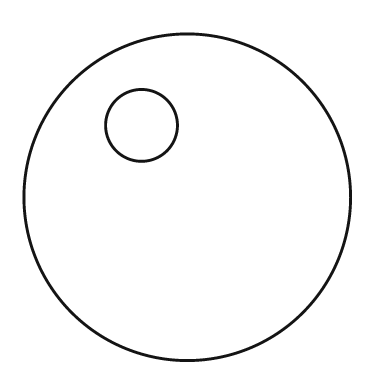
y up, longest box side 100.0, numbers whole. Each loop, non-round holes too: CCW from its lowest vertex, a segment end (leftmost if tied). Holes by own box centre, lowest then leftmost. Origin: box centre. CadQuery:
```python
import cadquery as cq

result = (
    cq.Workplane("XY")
    .moveTo(0.0, 0.0)
    .circle(50.0)
    .moveTo(-14.0, 22.0)
    .circle(11.0)
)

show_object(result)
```